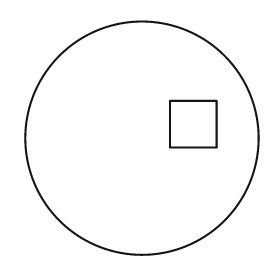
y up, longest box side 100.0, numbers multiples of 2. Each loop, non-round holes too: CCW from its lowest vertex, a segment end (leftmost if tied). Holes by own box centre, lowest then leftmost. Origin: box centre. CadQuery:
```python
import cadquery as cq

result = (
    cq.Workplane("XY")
    .moveTo(0.0, 0.0)
    .circle(50.0)
    .moveTo(12.0, -4.0)
    .lineTo(32.0, -4.0)
    .lineTo(32.0, 16.0)
    .lineTo(12.0, 16.0)
    .close()
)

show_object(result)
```